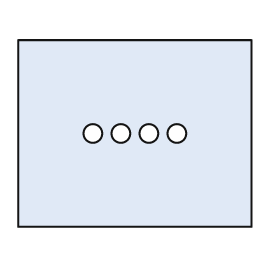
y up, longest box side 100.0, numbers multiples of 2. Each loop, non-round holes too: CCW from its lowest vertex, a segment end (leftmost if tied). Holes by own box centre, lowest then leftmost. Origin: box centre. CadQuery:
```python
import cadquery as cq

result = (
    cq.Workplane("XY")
    .moveTo(-50.0, -40.0)
    .lineTo(50.0, -40.0)
    .lineTo(50.0, 40.0)
    .lineTo(-50.0, 40.0)
    .close()
    .moveTo(-18.0, 0.0)
    .circle(4.0)
    .moveTo(-6.0, 0.0)
    .circle(4.0)
    .moveTo(6.0, 0.0)
    .circle(4.0)
    .moveTo(18.0, 0.0)
    .circle(4.0)
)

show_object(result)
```